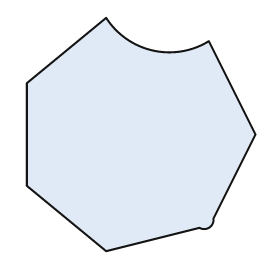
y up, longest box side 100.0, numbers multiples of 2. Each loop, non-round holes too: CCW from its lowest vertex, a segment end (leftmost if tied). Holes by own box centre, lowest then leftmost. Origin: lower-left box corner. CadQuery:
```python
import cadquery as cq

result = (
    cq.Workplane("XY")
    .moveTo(34.0, 0.0)
    .lineTo(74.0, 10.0)
    .threePointArc((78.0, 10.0), (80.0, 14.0))
    .lineTo(98.0, 50.0)
    .lineTo(78.0, 90.0)
    .threePointArc((54.0, 86.0), (34.0, 100.0))
    .lineTo(0.0, 72.0)
    .lineTo(0.0, 28.0)
    .close()
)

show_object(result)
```